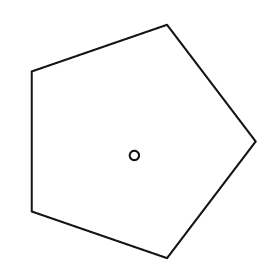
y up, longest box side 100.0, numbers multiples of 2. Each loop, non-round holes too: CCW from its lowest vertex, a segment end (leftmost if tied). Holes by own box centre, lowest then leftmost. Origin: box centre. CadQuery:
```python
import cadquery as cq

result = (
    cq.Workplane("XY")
    .moveTo(10.0, -50.0)
    .lineTo(48.0, 0.0)
    .lineTo(10.0, 50.0)
    .lineTo(-48.0, 30.0)
    .lineTo(-48.0, -30.0)
    .close()
    .moveTo(-4.0, -6.0)
    .circle(2.0)
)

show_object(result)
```